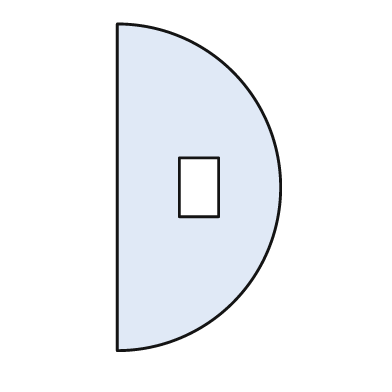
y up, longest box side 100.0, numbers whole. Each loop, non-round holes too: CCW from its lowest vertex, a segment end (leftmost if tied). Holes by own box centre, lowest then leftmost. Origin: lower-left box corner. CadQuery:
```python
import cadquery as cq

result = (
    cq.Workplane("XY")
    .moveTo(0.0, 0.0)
    .threePointArc((50.0, 50.0), (0.0, 100.0))
    .close()
    .moveTo(19.0, 41.0)
    .lineTo(31.0, 41.0)
    .lineTo(31.0, 59.0)
    .lineTo(19.0, 59.0)
    .close()
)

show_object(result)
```